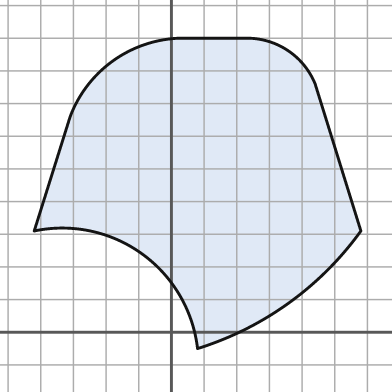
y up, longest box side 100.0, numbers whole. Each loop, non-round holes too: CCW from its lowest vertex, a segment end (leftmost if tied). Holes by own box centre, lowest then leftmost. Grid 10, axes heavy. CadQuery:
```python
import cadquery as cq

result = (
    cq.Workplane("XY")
    .moveTo(8.0, -5.0)
    .threePointArc((36.0, 9.0), (58.0, 31.0))
    .lineTo(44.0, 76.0)
    .threePointArc((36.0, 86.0), (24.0, 90.0))
    .lineTo(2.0, 90.0)
    .threePointArc((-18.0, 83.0), (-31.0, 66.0))
    .lineTo(-42.0, 31.0)
    .threePointArc((-9.0, 24.0), (8.0, -5.0))
    .close()
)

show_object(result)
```